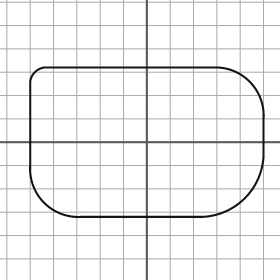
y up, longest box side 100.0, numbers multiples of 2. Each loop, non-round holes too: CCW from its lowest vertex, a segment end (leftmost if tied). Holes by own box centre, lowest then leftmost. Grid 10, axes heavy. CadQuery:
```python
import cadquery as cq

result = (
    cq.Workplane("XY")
    .moveTo(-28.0, -32.0)
    .lineTo(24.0, -32.0)
    .threePointArc((42.0, -24.0), (50.0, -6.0))
    .lineTo(50.0, 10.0)
    .threePointArc((44.0, 26.0), (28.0, 32.0))
    .lineTo(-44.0, 32.0)
    .threePointArc((-48.0, 30.0), (-50.0, 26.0))
    .lineTo(-50.0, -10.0)
    .threePointArc((-44.0, -26.0), (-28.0, -32.0))
    .close()
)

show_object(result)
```